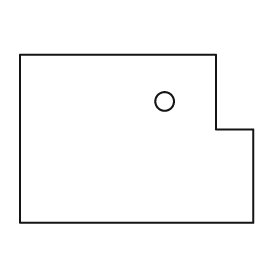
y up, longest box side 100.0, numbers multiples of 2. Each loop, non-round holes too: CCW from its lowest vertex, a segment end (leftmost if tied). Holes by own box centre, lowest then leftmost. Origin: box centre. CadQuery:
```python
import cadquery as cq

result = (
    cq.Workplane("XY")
    .moveTo(-50.0, -36.0)
    .lineTo(50.0, -36.0)
    .lineTo(50.0, 4.0)
    .lineTo(34.0, 4.0)
    .lineTo(34.0, 36.0)
    .lineTo(-50.0, 36.0)
    .close()
    .moveTo(12.0, 16.0)
    .circle(4.0)
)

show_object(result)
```